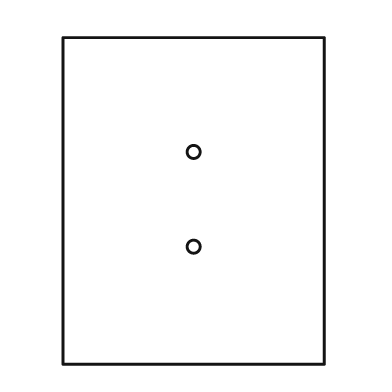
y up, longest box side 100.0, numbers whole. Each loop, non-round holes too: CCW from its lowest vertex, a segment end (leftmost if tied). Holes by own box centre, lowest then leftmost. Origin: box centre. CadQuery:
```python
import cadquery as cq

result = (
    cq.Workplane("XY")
    .moveTo(-40.0, -50.0)
    .lineTo(40.0, -50.0)
    .lineTo(40.0, 50.0)
    .lineTo(-40.0, 50.0)
    .close()
    .moveTo(0.0, -14.0)
    .circle(2.0)
    .moveTo(0.0, 15.0)
    .circle(2.0)
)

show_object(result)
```